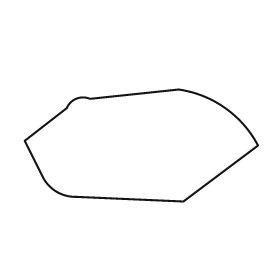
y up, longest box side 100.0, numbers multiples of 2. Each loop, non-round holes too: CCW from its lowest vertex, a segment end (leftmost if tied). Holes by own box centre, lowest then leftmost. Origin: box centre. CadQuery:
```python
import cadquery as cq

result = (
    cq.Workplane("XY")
    .moveTo(18.0, -24.0)
    .lineTo(50.0, 0.0)
    .threePointArc((36.0, 16.0), (16.0, 24.0))
    .lineTo(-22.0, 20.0)
    .threePointArc((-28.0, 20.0), (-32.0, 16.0))
    .lineTo(-50.0, 2.0)
    .lineTo(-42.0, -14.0)
    .threePointArc((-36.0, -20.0), (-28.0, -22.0))
    .close()
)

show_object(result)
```